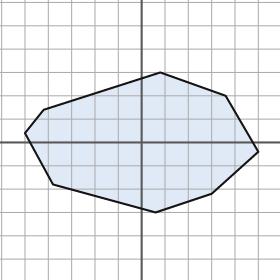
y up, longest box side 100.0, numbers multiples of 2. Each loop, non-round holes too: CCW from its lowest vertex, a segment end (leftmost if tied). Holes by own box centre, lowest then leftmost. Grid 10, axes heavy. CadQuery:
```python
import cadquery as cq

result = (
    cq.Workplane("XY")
    .moveTo(6.0, -30.0)
    .lineTo(30.0, -22.0)
    .lineTo(50.0, -4.0)
    .lineTo(36.0, 20.0)
    .lineTo(8.0, 30.0)
    .lineTo(-42.0, 14.0)
    .lineTo(-50.0, 4.0)
    .lineTo(-38.0, -18.0)
    .close()
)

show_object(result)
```